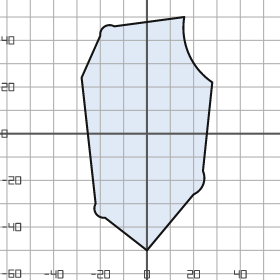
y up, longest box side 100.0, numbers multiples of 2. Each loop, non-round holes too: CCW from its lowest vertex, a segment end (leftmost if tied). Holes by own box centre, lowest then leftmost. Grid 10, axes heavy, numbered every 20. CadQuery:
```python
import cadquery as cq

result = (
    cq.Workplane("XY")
    .moveTo(0.0, -50.0)
    .lineTo(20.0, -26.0)
    .threePointArc((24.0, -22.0), (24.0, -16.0))
    .lineTo(28.0, 22.0)
    .threePointArc((18.0, 34.0), (16.0, 50.0))
    .lineTo(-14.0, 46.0)
    .threePointArc((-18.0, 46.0), (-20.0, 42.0))
    .lineTo(-28.0, 24.0)
    .lineTo(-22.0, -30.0)
    .threePointArc((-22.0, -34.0), (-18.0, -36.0))
    .close()
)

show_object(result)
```